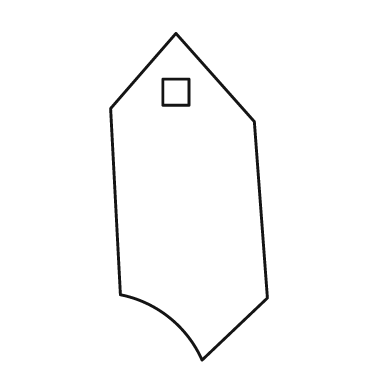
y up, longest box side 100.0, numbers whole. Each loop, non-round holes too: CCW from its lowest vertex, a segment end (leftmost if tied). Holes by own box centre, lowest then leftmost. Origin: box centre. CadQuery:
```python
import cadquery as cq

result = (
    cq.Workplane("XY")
    .moveTo(4.0, -50.0)
    .lineTo(24.0, -31.0)
    .lineTo(20.0, 23.0)
    .lineTo(-4.0, 50.0)
    .lineTo(-24.0, 27.0)
    .lineTo(-21.0, -30.0)
    .threePointArc((-6.0, -37.0), (4.0, -50.0))
    .close()
    .moveTo(-8.0, 28.0)
    .lineTo(0.0, 28.0)
    .lineTo(0.0, 36.0)
    .lineTo(-8.0, 36.0)
    .close()
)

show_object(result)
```